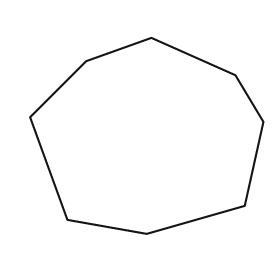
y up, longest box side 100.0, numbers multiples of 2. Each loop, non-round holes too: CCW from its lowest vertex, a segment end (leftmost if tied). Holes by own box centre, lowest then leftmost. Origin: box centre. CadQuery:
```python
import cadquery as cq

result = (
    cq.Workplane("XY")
    .moveTo(0.0, -42.0)
    .lineTo(42.0, -30.0)
    .lineTo(50.0, 6.0)
    .lineTo(38.0, 26.0)
    .lineTo(2.0, 42.0)
    .lineTo(-26.0, 32.0)
    .lineTo(-50.0, 8.0)
    .lineTo(-34.0, -36.0)
    .close()
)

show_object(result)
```